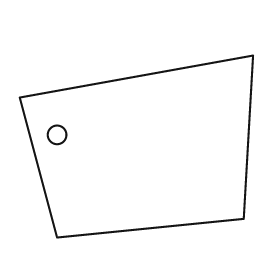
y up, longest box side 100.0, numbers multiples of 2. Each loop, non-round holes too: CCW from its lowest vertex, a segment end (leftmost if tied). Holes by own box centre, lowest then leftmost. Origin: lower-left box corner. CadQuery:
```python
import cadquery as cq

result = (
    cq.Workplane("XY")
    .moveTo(16.0, 0.0)
    .lineTo(96.0, 8.0)
    .lineTo(100.0, 78.0)
    .lineTo(0.0, 60.0)
    .close()
    .moveTo(16.0, 44.0)
    .circle(4.0)
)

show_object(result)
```